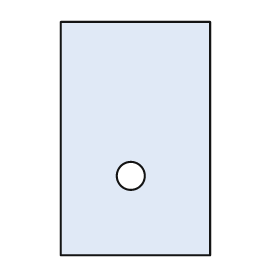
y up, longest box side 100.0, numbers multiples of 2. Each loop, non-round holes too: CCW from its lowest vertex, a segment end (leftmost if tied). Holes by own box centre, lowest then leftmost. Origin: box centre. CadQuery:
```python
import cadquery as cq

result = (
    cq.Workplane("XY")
    .moveTo(-32.0, -50.0)
    .lineTo(32.0, -50.0)
    .lineTo(32.0, 50.0)
    .lineTo(-32.0, 50.0)
    .close()
    .moveTo(-2.0, -16.0)
    .circle(6.0)
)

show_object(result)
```